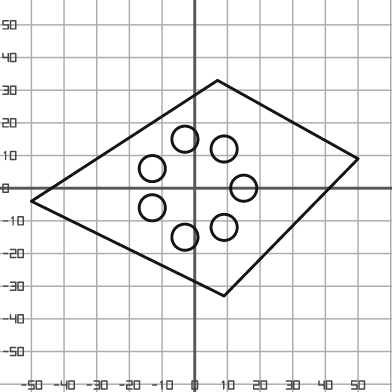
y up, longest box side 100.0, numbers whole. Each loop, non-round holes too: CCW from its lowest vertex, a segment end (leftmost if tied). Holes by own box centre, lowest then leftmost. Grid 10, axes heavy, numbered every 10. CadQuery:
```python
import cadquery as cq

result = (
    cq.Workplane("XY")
    .moveTo(9.0, -33.0)
    .lineTo(50.0, 9.0)
    .lineTo(7.0, 33.0)
    .lineTo(-50.0, -4.0)
    .close()
    .moveTo(-3.0, -15.0)
    .circle(4.0)
    .moveTo(9.0, -12.0)
    .circle(4.0)
    .moveTo(-13.0, -6.0)
    .circle(4.0)
    .moveTo(15.0, 0.0)
    .circle(4.0)
    .moveTo(-13.0, 6.0)
    .circle(4.0)
    .moveTo(9.0, 12.0)
    .circle(4.0)
    .moveTo(-3.0, 15.0)
    .circle(4.0)
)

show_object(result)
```